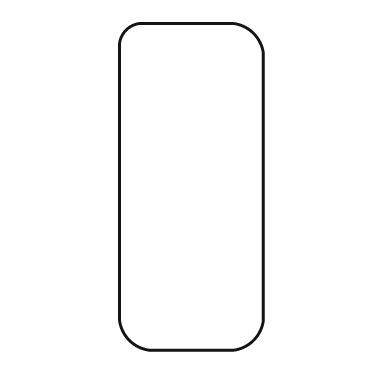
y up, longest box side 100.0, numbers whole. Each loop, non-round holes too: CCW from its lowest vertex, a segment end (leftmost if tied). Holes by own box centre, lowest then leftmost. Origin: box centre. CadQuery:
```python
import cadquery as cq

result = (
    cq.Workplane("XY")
    .moveTo(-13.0, -50.0)
    .lineTo(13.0, -50.0)
    .threePointArc((19.0, -47.0), (22.0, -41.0))
    .lineTo(22.0, 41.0)
    .threePointArc((19.0, 47.0), (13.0, 50.0))
    .lineTo(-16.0, 50.0)
    .threePointArc((-20.0, 48.0), (-22.0, 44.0))
    .lineTo(-22.0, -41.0)
    .threePointArc((-19.0, -47.0), (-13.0, -50.0))
    .close()
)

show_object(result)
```